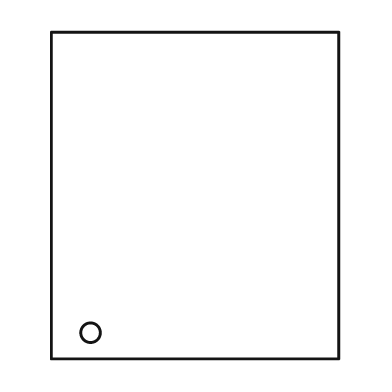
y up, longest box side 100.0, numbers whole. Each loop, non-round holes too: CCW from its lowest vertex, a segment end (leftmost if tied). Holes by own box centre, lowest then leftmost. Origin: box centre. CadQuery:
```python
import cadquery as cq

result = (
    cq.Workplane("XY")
    .moveTo(-44.0, -50.0)
    .lineTo(44.0, -50.0)
    .lineTo(44.0, 50.0)
    .lineTo(-44.0, 50.0)
    .close()
    .moveTo(-32.0, -42.0)
    .circle(3.0)
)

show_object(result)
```